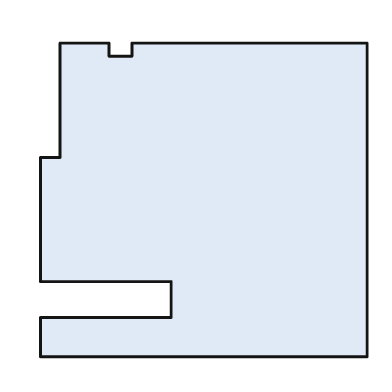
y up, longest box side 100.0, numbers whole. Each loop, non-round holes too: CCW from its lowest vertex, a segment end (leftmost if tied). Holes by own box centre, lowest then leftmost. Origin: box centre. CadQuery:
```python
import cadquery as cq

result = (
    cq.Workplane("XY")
    .moveTo(-50.0, -48.0)
    .lineTo(50.0, -48.0)
    .lineTo(50.0, 48.0)
    .lineTo(-22.0, 48.0)
    .lineTo(-22.0, 44.0)
    .lineTo(-29.0, 44.0)
    .lineTo(-29.0, 48.0)
    .lineTo(-44.0, 48.0)
    .lineTo(-44.0, 13.0)
    .lineTo(-50.0, 13.0)
    .lineTo(-50.0, -25.0)
    .lineTo(-10.0, -25.0)
    .lineTo(-10.0, -36.0)
    .lineTo(-50.0, -36.0)
    .close()
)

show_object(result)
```